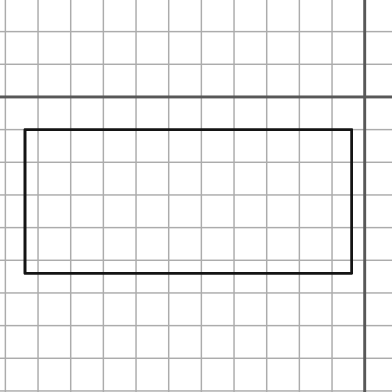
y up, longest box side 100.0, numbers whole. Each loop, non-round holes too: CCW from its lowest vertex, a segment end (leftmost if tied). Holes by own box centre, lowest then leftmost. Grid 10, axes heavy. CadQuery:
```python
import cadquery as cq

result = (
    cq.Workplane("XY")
    .moveTo(-104.0, -54.0)
    .lineTo(-4.0, -54.0)
    .lineTo(-4.0, -10.0)
    .lineTo(-104.0, -10.0)
    .close()
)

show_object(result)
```